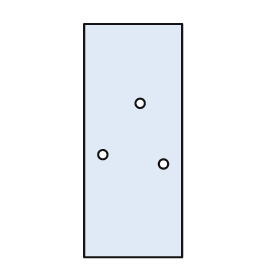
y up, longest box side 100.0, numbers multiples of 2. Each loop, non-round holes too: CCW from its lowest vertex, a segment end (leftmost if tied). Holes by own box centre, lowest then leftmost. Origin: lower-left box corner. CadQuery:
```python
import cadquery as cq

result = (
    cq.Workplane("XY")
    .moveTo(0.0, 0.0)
    .lineTo(42.0, 0.0)
    .lineTo(42.0, 100.0)
    .lineTo(0.0, 100.0)
    .close()
    .moveTo(34.0, 40.0)
    .circle(2.0)
    .moveTo(8.0, 44.0)
    .circle(2.0)
    .moveTo(24.0, 66.0)
    .circle(2.0)
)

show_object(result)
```